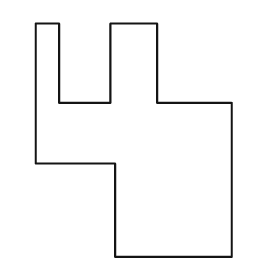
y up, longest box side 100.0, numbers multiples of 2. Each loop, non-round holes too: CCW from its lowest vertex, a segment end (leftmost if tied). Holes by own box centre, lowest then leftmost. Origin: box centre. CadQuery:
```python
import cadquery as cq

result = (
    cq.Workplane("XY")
    .moveTo(-8.0, -50.0)
    .lineTo(42.0, -50.0)
    .lineTo(42.0, 16.0)
    .lineTo(10.0, 16.0)
    .lineTo(10.0, 50.0)
    .lineTo(-10.0, 50.0)
    .lineTo(-10.0, 16.0)
    .lineTo(-32.0, 16.0)
    .lineTo(-32.0, 50.0)
    .lineTo(-42.0, 50.0)
    .lineTo(-42.0, -10.0)
    .lineTo(-8.0, -10.0)
    .close()
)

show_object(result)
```